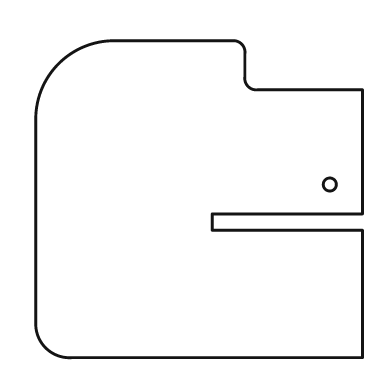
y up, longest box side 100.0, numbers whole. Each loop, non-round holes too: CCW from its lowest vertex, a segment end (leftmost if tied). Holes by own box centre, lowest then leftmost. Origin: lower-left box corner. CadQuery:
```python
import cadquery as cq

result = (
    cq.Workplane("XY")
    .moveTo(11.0, 0.0)
    .lineTo(100.0, 0.0)
    .lineTo(100.0, 39.0)
    .lineTo(54.0, 39.0)
    .lineTo(54.0, 44.0)
    .lineTo(100.0, 44.0)
    .lineTo(100.0, 82.0)
    .lineTo(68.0, 82.0)
    .threePointArc((65.0, 83.0), (64.0, 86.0))
    .lineTo(64.0, 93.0)
    .threePointArc((63.0, 96.0), (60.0, 97.0))
    .lineTo(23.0, 97.0)
    .threePointArc((7.0, 90.0), (0.0, 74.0))
    .lineTo(0.0, 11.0)
    .threePointArc((3.0, 3.0), (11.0, 0.0))
    .close()
    .moveTo(90.0, 53.0)
    .circle(2.0)
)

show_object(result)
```